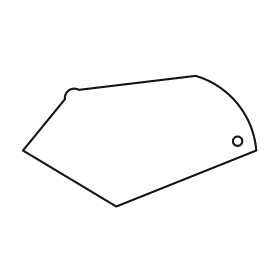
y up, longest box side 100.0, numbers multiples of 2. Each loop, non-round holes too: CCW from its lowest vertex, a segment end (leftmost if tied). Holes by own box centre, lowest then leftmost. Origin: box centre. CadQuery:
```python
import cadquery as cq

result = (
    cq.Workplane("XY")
    .moveTo(-10.0, -28.0)
    .lineTo(50.0, -4.0)
    .threePointArc((42.0, 16.0), (24.0, 28.0))
    .lineTo(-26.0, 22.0)
    .threePointArc((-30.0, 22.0), (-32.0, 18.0))
    .lineTo(-50.0, -4.0)
    .close()
    .moveTo(42.0, 0.0)
    .circle(2.0)
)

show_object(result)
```